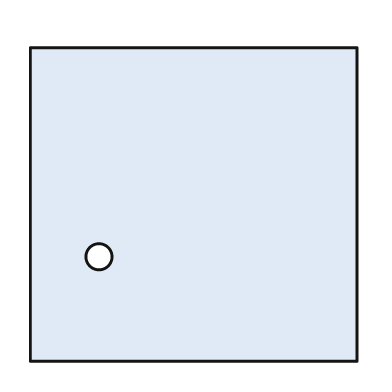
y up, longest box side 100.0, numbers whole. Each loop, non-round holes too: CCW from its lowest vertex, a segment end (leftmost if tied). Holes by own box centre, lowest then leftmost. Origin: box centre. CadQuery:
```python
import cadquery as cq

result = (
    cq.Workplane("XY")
    .moveTo(-50.0, -48.0)
    .lineTo(50.0, -48.0)
    .lineTo(50.0, 48.0)
    .lineTo(-50.0, 48.0)
    .close()
    .moveTo(-29.0, -16.0)
    .circle(4.0)
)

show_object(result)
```